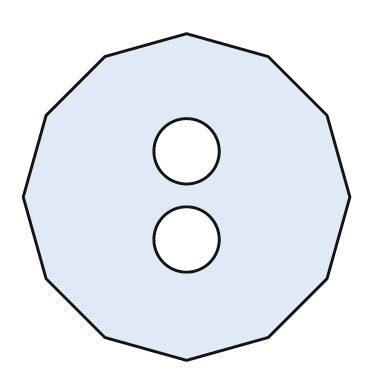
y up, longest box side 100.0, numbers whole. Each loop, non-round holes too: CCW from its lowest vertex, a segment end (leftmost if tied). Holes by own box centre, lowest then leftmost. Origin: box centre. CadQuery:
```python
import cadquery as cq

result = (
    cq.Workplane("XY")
    .moveTo(0.0, -50.0)
    .lineTo(25.0, -43.0)
    .lineTo(43.0, -25.0)
    .lineTo(50.0, 0.0)
    .lineTo(43.0, 25.0)
    .lineTo(25.0, 43.0)
    .lineTo(0.0, 50.0)
    .lineTo(-25.0, 43.0)
    .lineTo(-43.0, 25.0)
    .lineTo(-50.0, 0.0)
    .lineTo(-43.0, -25.0)
    .lineTo(-25.0, -43.0)
    .close()
    .moveTo(0.0, -13.0)
    .circle(10.0)
    .moveTo(0.0, 14.0)
    .circle(10.0)
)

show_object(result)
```